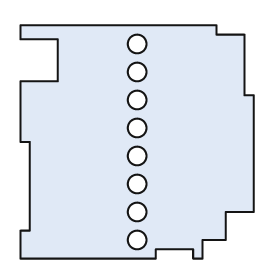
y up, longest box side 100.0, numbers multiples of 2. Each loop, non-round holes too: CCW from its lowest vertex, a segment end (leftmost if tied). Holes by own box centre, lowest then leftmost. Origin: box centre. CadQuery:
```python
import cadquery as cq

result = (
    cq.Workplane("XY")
    .moveTo(-50.0, -50.0)
    .lineTo(8.0, -50.0)
    .lineTo(8.0, -46.0)
    .lineTo(24.0, -46.0)
    .lineTo(24.0, -50.0)
    .lineTo(28.0, -50.0)
    .lineTo(28.0, -42.0)
    .lineTo(38.0, -42.0)
    .lineTo(38.0, -30.0)
    .lineTo(50.0, -30.0)
    .lineTo(50.0, 20.0)
    .lineTo(46.0, 20.0)
    .lineTo(46.0, 46.0)
    .lineTo(34.0, 46.0)
    .lineTo(34.0, 50.0)
    .lineTo(-50.0, 50.0)
    .lineTo(-50.0, 44.0)
    .lineTo(-34.0, 44.0)
    .lineTo(-34.0, 26.0)
    .lineTo(-50.0, 26.0)
    .lineTo(-50.0, 0.0)
    .lineTo(-46.0, 0.0)
    .lineTo(-46.0, -38.0)
    .lineTo(-50.0, -38.0)
    .close()
    .moveTo(0.0, -42.0)
    .circle(4.0)
    .moveTo(0.0, -30.0)
    .circle(4.0)
    .moveTo(0.0, -18.0)
    .circle(4.0)
    .moveTo(0.0, -6.0)
    .circle(4.0)
    .moveTo(0.0, 6.0)
    .circle(4.0)
    .moveTo(0.0, 18.0)
    .circle(4.0)
    .moveTo(0.0, 30.0)
    .circle(4.0)
    .moveTo(0.0, 42.0)
    .circle(4.0)
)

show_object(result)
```